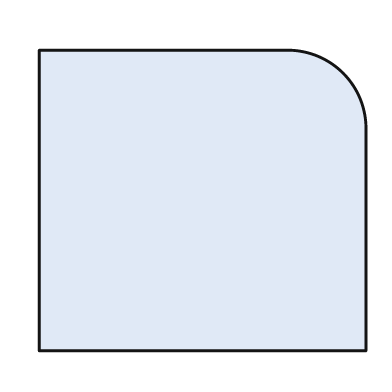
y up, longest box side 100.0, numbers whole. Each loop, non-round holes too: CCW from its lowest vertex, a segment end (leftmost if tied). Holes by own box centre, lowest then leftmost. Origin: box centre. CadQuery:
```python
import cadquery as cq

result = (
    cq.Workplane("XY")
    .moveTo(-50.0, -46.0)
    .lineTo(50.0, -46.0)
    .lineTo(50.0, 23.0)
    .threePointArc((43.0, 39.0), (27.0, 46.0))
    .lineTo(-50.0, 46.0)
    .close()
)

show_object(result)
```